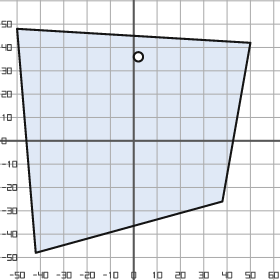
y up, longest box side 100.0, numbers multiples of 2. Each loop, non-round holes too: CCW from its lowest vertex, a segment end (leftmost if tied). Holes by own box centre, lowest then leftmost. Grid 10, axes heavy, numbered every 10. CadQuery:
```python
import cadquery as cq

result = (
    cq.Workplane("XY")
    .moveTo(-42.0, -48.0)
    .lineTo(38.0, -26.0)
    .lineTo(50.0, 42.0)
    .lineTo(-50.0, 48.0)
    .close()
    .moveTo(2.0, 36.0)
    .circle(2.0)
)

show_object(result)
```